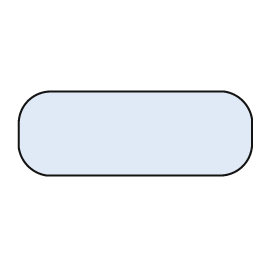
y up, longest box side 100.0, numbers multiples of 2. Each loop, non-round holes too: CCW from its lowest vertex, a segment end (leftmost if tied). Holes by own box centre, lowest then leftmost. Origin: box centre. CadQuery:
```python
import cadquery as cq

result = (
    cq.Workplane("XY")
    .moveTo(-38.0, -18.0)
    .lineTo(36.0, -18.0)
    .threePointArc((46.0, -14.0), (50.0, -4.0))
    .lineTo(50.0, 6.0)
    .threePointArc((46.0, 14.0), (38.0, 18.0))
    .lineTo(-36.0, 18.0)
    .threePointArc((-46.0, 14.0), (-50.0, 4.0))
    .lineTo(-50.0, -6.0)
    .threePointArc((-46.0, -14.0), (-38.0, -18.0))
    .close()
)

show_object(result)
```